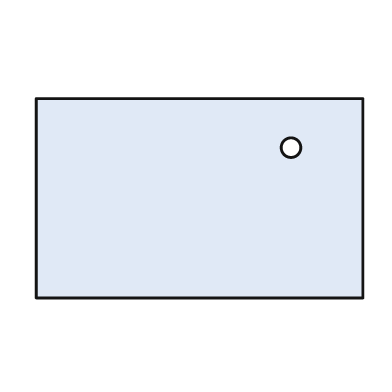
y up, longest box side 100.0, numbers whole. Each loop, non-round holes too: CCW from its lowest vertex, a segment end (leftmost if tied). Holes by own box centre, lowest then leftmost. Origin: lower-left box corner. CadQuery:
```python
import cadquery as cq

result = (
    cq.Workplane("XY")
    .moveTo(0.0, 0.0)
    .lineTo(100.0, 0.0)
    .lineTo(100.0, 61.0)
    .lineTo(0.0, 61.0)
    .close()
    .moveTo(78.0, 46.0)
    .circle(3.0)
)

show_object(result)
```